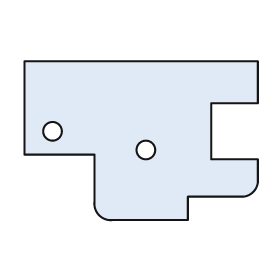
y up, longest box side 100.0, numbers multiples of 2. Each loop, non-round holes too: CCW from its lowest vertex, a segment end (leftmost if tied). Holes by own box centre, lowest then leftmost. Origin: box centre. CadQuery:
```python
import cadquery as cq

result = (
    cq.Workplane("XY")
    .moveTo(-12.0, -34.0)
    .lineTo(20.0, -34.0)
    .lineTo(20.0, -24.0)
    .lineTo(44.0, -24.0)
    .threePointArc((48.0, -22.0), (50.0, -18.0))
    .lineTo(50.0, -8.0)
    .lineTo(30.0, -8.0)
    .lineTo(30.0, 16.0)
    .lineTo(50.0, 16.0)
    .lineTo(50.0, 34.0)
    .lineTo(-50.0, 34.0)
    .lineTo(-50.0, -6.0)
    .lineTo(-20.0, -6.0)
    .lineTo(-20.0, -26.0)
    .threePointArc((-18.0, -32.0), (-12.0, -34.0))
    .close()
    .moveTo(2.0, -4.0)
    .circle(4.0)
    .moveTo(-38.0, 4.0)
    .circle(4.0)
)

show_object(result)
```